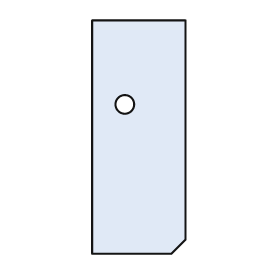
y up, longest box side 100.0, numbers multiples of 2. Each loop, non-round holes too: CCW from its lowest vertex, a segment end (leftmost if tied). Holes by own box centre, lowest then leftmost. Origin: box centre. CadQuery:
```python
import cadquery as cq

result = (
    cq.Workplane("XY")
    .moveTo(-20.0, -50.0)
    .lineTo(14.0, -50.0)
    .lineTo(20.0, -44.0)
    .lineTo(20.0, 50.0)
    .lineTo(-20.0, 50.0)
    .close()
    .moveTo(-6.0, 14.0)
    .circle(4.0)
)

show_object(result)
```